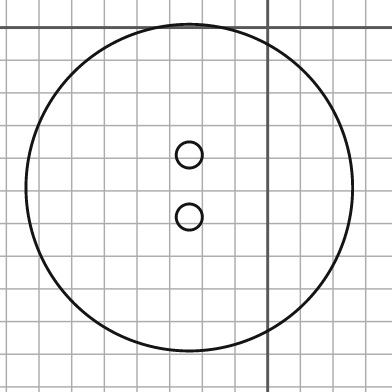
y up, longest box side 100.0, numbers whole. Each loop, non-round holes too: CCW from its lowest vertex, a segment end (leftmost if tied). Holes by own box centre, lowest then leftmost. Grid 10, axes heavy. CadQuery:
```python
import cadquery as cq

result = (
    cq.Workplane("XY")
    .moveTo(-24.0, -49.0)
    .circle(50.0)
    .moveTo(-24.0, -58.0)
    .circle(4.0)
    .moveTo(-24.0, -39.0)
    .circle(4.0)
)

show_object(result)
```